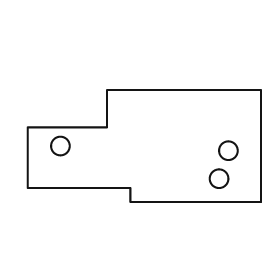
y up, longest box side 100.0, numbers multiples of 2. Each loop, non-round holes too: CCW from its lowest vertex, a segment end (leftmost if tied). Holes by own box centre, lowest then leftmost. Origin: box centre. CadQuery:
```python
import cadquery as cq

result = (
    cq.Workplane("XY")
    .moveTo(-6.0, -24.0)
    .lineTo(50.0, -24.0)
    .lineTo(50.0, 24.0)
    .lineTo(-16.0, 24.0)
    .lineTo(-16.0, 8.0)
    .lineTo(-50.0, 8.0)
    .lineTo(-50.0, -18.0)
    .lineTo(-6.0, -18.0)
    .close()
    .moveTo(32.0, -14.0)
    .circle(4.0)
    .moveTo(36.0, -2.0)
    .circle(4.0)
    .moveTo(-36.0, 0.0)
    .circle(4.0)
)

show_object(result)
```